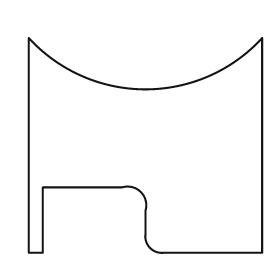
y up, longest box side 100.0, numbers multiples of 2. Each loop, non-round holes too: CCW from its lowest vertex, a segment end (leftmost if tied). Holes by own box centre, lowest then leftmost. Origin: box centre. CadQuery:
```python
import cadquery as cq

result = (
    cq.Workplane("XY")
    .moveTo(-50.0, -46.0)
    .lineTo(-44.0, -46.0)
    .lineTo(-44.0, -18.0)
    .lineTo(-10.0, -18.0)
    .threePointArc((-2.0, -20.0), (0.0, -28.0))
    .lineTo(0.0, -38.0)
    .threePointArc((2.0, -44.0), (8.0, -46.0))
    .lineTo(50.0, -46.0)
    .lineTo(50.0, 46.0)
    .threePointArc((0.0, 24.0), (-50.0, 46.0))
    .close()
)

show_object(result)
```